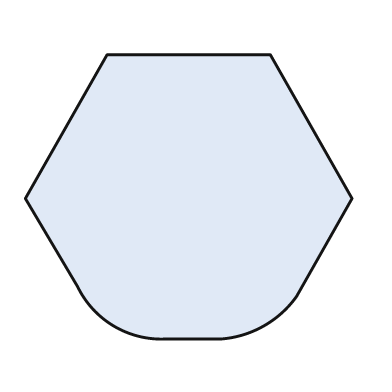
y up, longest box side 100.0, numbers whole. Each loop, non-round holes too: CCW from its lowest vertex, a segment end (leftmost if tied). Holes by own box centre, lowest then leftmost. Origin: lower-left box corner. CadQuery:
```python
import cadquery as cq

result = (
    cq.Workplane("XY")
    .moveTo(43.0, 0.0)
    .lineTo(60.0, 0.0)
    .threePointArc((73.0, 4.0), (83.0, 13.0))
    .lineTo(100.0, 43.0)
    .lineTo(75.0, 87.0)
    .lineTo(25.0, 87.0)
    .lineTo(0.0, 43.0)
    .lineTo(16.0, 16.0)
    .threePointArc((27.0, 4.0), (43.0, 0.0))
    .close()
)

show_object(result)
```